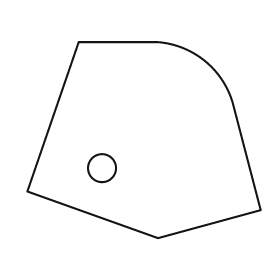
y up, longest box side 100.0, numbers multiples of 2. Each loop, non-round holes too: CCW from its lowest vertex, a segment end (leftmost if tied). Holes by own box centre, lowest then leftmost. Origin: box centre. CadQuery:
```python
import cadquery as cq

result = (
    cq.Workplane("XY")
    .moveTo(6.0, -42.0)
    .lineTo(50.0, -30.0)
    .lineTo(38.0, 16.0)
    .threePointArc((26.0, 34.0), (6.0, 42.0))
    .lineTo(-28.0, 42.0)
    .lineTo(-50.0, -22.0)
    .close()
    .moveTo(-18.0, -12.0)
    .circle(6.0)
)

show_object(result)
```